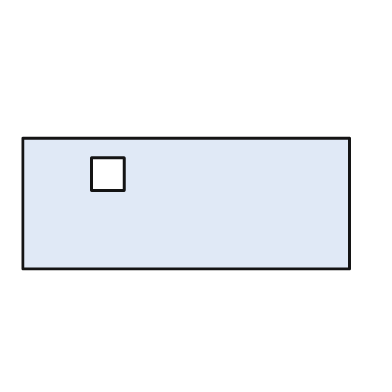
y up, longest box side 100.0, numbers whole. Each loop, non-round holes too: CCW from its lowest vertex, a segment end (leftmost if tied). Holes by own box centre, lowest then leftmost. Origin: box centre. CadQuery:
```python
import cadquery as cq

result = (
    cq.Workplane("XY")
    .moveTo(-50.0, -20.0)
    .lineTo(50.0, -20.0)
    .lineTo(50.0, 20.0)
    .lineTo(-50.0, 20.0)
    .close()
    .moveTo(-29.0, 4.0)
    .lineTo(-19.0, 4.0)
    .lineTo(-19.0, 14.0)
    .lineTo(-29.0, 14.0)
    .close()
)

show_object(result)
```